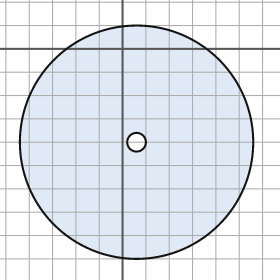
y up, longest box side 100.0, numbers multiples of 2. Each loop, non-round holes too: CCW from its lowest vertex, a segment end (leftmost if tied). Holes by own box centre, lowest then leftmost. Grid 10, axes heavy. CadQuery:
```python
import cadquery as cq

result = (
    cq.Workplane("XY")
    .moveTo(6.0, -40.0)
    .circle(50.0)
    .moveTo(6.0, -40.0)
    .circle(4.0)
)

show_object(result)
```